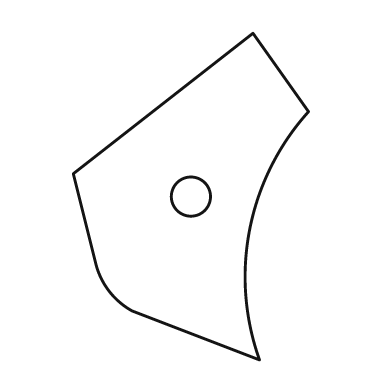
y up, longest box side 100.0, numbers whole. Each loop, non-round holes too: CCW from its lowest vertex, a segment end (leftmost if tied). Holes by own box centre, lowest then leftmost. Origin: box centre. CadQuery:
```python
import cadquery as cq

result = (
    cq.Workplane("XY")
    .moveTo(21.0, -50.0)
    .threePointArc((18.0, -10.0), (36.0, 26.0))
    .lineTo(19.0, 50.0)
    .lineTo(-36.0, 7.0)
    .lineTo(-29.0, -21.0)
    .threePointArc((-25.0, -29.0), (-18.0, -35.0))
    .close()
    .moveTo(0.0, 0.0)
    .circle(6.0)
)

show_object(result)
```